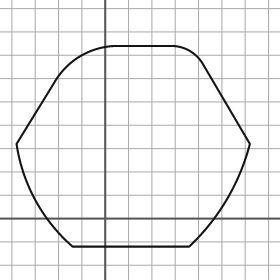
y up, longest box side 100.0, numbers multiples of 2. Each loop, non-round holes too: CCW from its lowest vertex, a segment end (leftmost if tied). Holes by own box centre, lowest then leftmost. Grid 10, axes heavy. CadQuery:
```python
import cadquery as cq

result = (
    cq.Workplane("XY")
    .moveTo(-14.0, -12.0)
    .lineTo(36.0, -12.0)
    .threePointArc((52.0, 8.0), (62.0, 32.0))
    .lineTo(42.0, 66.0)
    .threePointArc((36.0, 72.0), (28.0, 74.0))
    .lineTo(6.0, 74.0)
    .threePointArc((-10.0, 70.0), (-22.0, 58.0))
    .lineTo(-38.0, 32.0)
    .threePointArc((-30.0, 8.0), (-14.0, -12.0))
    .close()
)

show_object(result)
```